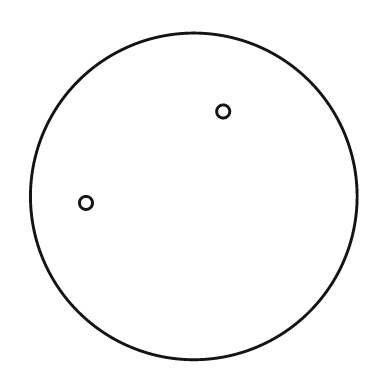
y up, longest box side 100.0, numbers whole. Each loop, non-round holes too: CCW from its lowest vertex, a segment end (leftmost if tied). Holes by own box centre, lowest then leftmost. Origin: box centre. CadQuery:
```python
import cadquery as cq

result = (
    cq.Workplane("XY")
    .moveTo(0.0, 0.0)
    .circle(50.0)
    .moveTo(-33.0, -2.0)
    .circle(2.0)
    .moveTo(9.0, 26.0)
    .circle(2.0)
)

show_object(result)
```